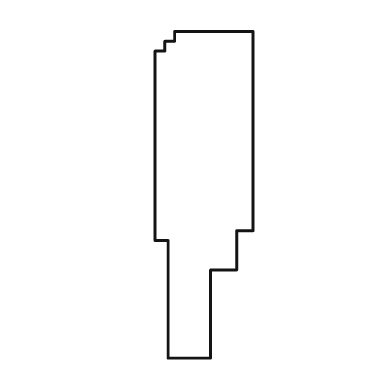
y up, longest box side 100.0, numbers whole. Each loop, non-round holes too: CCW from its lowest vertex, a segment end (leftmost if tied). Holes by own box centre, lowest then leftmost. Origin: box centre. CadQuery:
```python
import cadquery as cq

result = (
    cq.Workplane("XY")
    .moveTo(-11.0, -50.0)
    .lineTo(2.0, -50.0)
    .lineTo(2.0, -23.0)
    .lineTo(10.0, -23.0)
    .lineTo(10.0, -11.0)
    .lineTo(15.0, -11.0)
    .lineTo(15.0, 50.0)
    .lineTo(-9.0, 50.0)
    .lineTo(-9.0, 47.0)
    .lineTo(-12.0, 47.0)
    .lineTo(-12.0, 44.0)
    .lineTo(-15.0, 44.0)
    .lineTo(-15.0, -14.0)
    .lineTo(-11.0, -14.0)
    .close()
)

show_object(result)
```